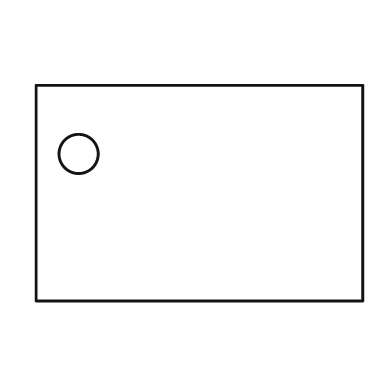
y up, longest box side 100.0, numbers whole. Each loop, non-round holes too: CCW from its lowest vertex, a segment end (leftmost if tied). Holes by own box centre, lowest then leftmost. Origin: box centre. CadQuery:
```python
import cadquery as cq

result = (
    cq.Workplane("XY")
    .moveTo(-50.0, -33.0)
    .lineTo(50.0, -33.0)
    .lineTo(50.0, 33.0)
    .lineTo(-50.0, 33.0)
    .close()
    .moveTo(-37.0, 12.0)
    .circle(6.0)
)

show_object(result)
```